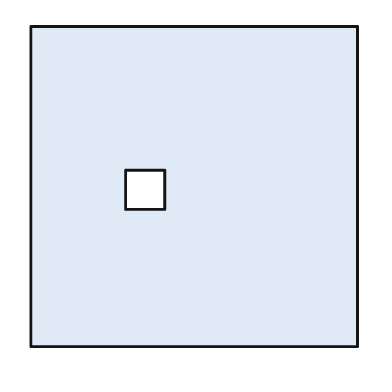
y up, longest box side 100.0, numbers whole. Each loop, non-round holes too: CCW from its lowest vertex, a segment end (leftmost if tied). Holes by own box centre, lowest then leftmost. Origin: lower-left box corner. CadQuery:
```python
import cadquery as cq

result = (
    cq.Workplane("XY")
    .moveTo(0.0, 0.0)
    .lineTo(100.0, 0.0)
    .lineTo(100.0, 98.0)
    .lineTo(0.0, 98.0)
    .close()
    .moveTo(29.0, 42.0)
    .lineTo(41.0, 42.0)
    .lineTo(41.0, 54.0)
    .lineTo(29.0, 54.0)
    .close()
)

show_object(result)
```